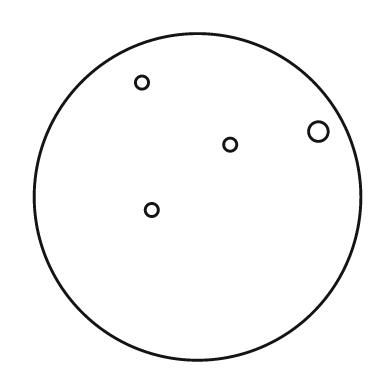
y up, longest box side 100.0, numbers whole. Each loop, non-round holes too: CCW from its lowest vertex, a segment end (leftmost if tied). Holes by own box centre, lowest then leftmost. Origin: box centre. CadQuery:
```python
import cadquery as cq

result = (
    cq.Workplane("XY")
    .moveTo(0.0, 0.0)
    .circle(50.0)
    .moveTo(-14.0, -4.0)
    .circle(2.0)
    .moveTo(10.0, 16.0)
    .circle(2.0)
    .moveTo(37.0, 20.0)
    .circle(3.0)
    .moveTo(-17.0, 35.0)
    .circle(2.0)
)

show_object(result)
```